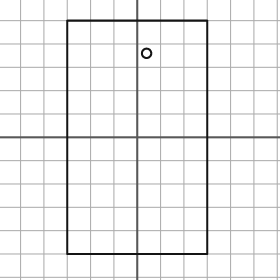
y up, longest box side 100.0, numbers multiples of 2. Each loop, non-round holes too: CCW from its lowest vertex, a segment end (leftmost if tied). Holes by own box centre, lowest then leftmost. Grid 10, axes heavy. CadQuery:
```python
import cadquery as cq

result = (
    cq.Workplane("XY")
    .moveTo(-30.0, -50.0)
    .lineTo(30.0, -50.0)
    .lineTo(30.0, 50.0)
    .lineTo(-30.0, 50.0)
    .close()
    .moveTo(4.0, 36.0)
    .circle(2.0)
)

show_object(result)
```